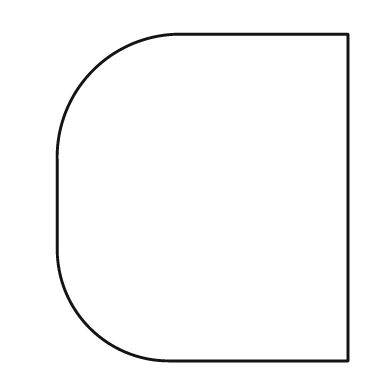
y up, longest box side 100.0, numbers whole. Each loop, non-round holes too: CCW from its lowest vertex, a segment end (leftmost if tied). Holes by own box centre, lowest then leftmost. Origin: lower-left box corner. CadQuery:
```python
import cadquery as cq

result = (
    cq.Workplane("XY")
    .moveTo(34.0, 0.0)
    .lineTo(89.0, 0.0)
    .lineTo(89.0, 100.0)
    .lineTo(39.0, 100.0)
    .threePointArc((11.0, 89.0), (0.0, 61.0))
    .lineTo(0.0, 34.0)
    .threePointArc((10.0, 10.0), (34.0, 0.0))
    .close()
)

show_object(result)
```